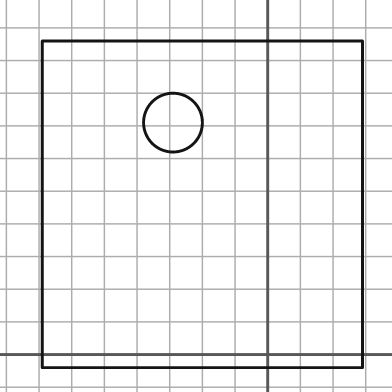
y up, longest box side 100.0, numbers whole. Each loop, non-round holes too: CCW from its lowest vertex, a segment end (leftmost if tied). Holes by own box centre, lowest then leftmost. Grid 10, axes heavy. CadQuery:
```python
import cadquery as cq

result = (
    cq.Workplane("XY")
    .moveTo(-69.0, -4.0)
    .lineTo(29.0, -4.0)
    .lineTo(29.0, 96.0)
    .lineTo(-69.0, 96.0)
    .close()
    .moveTo(-29.0, 71.0)
    .circle(9.0)
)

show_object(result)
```